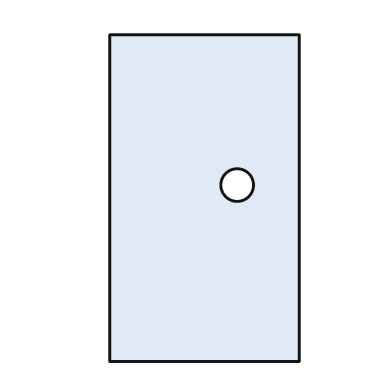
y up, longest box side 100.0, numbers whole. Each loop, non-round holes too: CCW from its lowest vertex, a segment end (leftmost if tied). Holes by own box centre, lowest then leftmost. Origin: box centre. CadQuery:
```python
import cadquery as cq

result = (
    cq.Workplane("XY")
    .moveTo(-29.0, -50.0)
    .lineTo(29.0, -50.0)
    .lineTo(29.0, 50.0)
    .lineTo(-29.0, 50.0)
    .close()
    .moveTo(10.0, 4.0)
    .circle(5.0)
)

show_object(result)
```